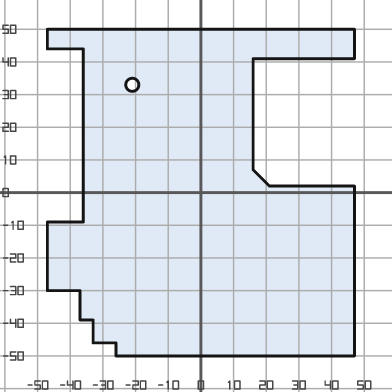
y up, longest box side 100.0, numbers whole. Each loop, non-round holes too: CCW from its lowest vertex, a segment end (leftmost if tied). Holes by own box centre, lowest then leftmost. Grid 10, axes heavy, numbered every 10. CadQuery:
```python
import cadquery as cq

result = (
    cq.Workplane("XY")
    .moveTo(-26.0, -50.0)
    .lineTo(47.0, -50.0)
    .lineTo(47.0, 2.0)
    .lineTo(21.0, 2.0)
    .lineTo(16.0, 7.0)
    .lineTo(16.0, 41.0)
    .lineTo(47.0, 41.0)
    .lineTo(47.0, 50.0)
    .lineTo(-47.0, 50.0)
    .lineTo(-47.0, 44.0)
    .lineTo(-36.0, 44.0)
    .lineTo(-36.0, -9.0)
    .lineTo(-47.0, -9.0)
    .lineTo(-47.0, -30.0)
    .lineTo(-37.0, -30.0)
    .lineTo(-37.0, -39.0)
    .lineTo(-33.0, -39.0)
    .lineTo(-33.0, -46.0)
    .lineTo(-26.0, -46.0)
    .close()
    .moveTo(-21.0, 33.0)
    .circle(2.0)
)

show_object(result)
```